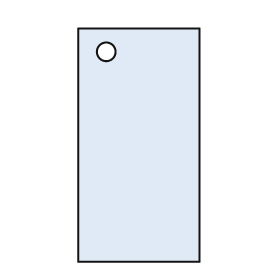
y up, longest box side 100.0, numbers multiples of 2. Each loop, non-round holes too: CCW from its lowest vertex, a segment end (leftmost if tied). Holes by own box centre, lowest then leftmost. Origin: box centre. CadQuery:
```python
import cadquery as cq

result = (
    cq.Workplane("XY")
    .moveTo(-26.0, -50.0)
    .lineTo(26.0, -50.0)
    .lineTo(26.0, 50.0)
    .lineTo(-26.0, 50.0)
    .close()
    .moveTo(-14.0, 40.0)
    .circle(4.0)
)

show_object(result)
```